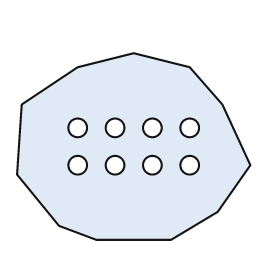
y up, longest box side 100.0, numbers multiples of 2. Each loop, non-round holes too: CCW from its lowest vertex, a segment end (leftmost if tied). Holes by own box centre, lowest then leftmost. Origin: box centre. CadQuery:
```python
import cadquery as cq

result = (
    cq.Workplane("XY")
    .moveTo(-16.0, -40.0)
    .lineTo(16.0, -40.0)
    .lineTo(36.0, -28.0)
    .lineTo(50.0, -8.0)
    .lineTo(38.0, 18.0)
    .lineTo(24.0, 34.0)
    .lineTo(0.0, 40.0)
    .lineTo(-24.0, 34.0)
    .lineTo(-48.0, 18.0)
    .lineTo(-50.0, -12.0)
    .lineTo(-32.0, -34.0)
    .close()
    .moveTo(-24.0, -8.0)
    .circle(4.0)
    .moveTo(-8.0, -8.0)
    .circle(4.0)
    .moveTo(8.0, -8.0)
    .circle(4.0)
    .moveTo(24.0, -8.0)
    .circle(4.0)
    .moveTo(-24.0, 8.0)
    .circle(4.0)
    .moveTo(-8.0, 8.0)
    .circle(4.0)
    .moveTo(8.0, 8.0)
    .circle(4.0)
    .moveTo(24.0, 8.0)
    .circle(4.0)
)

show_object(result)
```